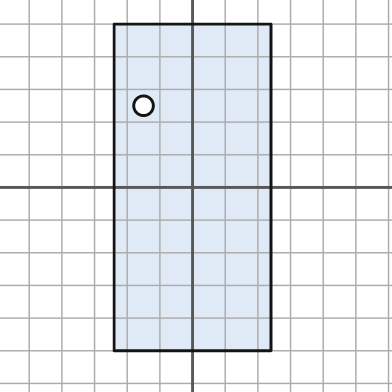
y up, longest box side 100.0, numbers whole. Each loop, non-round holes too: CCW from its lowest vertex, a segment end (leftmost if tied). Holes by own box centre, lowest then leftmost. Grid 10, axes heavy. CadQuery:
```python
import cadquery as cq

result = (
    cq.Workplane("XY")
    .moveTo(-24.0, -50.0)
    .lineTo(24.0, -50.0)
    .lineTo(24.0, 50.0)
    .lineTo(-24.0, 50.0)
    .close()
    .moveTo(-15.0, 25.0)
    .circle(3.0)
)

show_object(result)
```